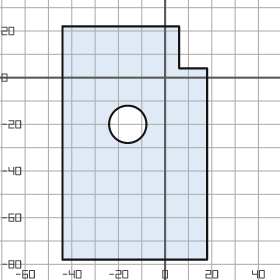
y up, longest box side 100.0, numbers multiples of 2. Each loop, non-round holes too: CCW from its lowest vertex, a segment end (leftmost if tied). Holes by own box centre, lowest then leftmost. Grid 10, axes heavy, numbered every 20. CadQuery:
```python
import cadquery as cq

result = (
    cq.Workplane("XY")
    .moveTo(-44.0, -78.0)
    .lineTo(18.0, -78.0)
    .lineTo(18.0, 4.0)
    .lineTo(6.0, 4.0)
    .lineTo(6.0, 22.0)
    .lineTo(-44.0, 22.0)
    .close()
    .moveTo(-16.0, -20.0)
    .circle(8.0)
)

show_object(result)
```